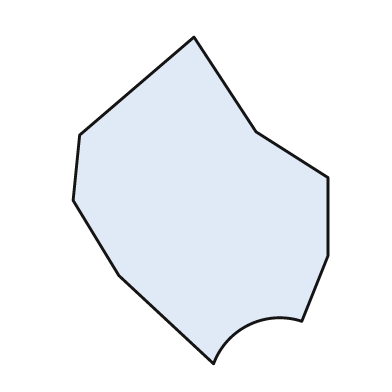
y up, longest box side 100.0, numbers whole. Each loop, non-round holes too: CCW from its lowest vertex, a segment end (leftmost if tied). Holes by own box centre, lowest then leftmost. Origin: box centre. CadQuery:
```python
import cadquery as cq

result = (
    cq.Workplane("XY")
    .moveTo(4.0, -50.0)
    .threePointArc((15.0, -38.0), (31.0, -37.0))
    .lineTo(39.0, -17.0)
    .lineTo(39.0, 7.0)
    .lineTo(17.0, 21.0)
    .lineTo(-2.0, 50.0)
    .lineTo(-37.0, 20.0)
    .lineTo(-39.0, 0.0)
    .lineTo(-25.0, -23.0)
    .close()
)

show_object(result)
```